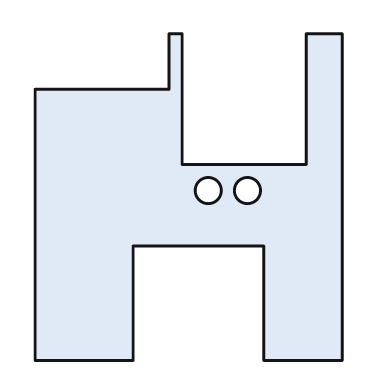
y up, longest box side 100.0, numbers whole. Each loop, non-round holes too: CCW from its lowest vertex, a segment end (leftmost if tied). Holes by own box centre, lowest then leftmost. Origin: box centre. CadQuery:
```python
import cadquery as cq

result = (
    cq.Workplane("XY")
    .moveTo(-47.0, -50.0)
    .lineTo(-17.0, -50.0)
    .lineTo(-17.0, -15.0)
    .lineTo(23.0, -15.0)
    .lineTo(23.0, -50.0)
    .lineTo(47.0, -50.0)
    .lineTo(47.0, 50.0)
    .lineTo(36.0, 50.0)
    .lineTo(36.0, 10.0)
    .lineTo(-2.0, 10.0)
    .lineTo(-2.0, 50.0)
    .lineTo(-6.0, 50.0)
    .lineTo(-6.0, 33.0)
    .lineTo(-47.0, 33.0)
    .close()
    .moveTo(6.0, 2.0)
    .circle(4.0)
    .moveTo(18.0, 2.0)
    .circle(4.0)
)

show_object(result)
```